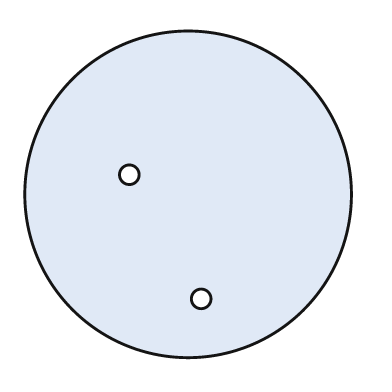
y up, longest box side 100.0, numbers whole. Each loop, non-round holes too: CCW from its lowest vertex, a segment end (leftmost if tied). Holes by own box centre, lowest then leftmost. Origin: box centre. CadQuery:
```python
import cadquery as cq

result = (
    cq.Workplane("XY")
    .moveTo(0.0, 0.0)
    .circle(50.0)
    .moveTo(4.0, -32.0)
    .circle(3.0)
    .moveTo(-18.0, 6.0)
    .circle(3.0)
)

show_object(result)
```